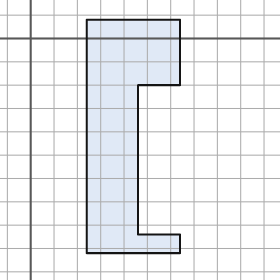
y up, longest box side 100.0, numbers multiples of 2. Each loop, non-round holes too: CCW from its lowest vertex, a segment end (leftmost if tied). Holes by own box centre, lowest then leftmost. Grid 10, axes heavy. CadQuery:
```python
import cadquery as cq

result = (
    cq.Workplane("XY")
    .moveTo(24.0, -92.0)
    .lineTo(64.0, -92.0)
    .lineTo(64.0, -84.0)
    .lineTo(46.0, -84.0)
    .lineTo(46.0, -20.0)
    .lineTo(64.0, -20.0)
    .lineTo(64.0, 8.0)
    .lineTo(24.0, 8.0)
    .close()
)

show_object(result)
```